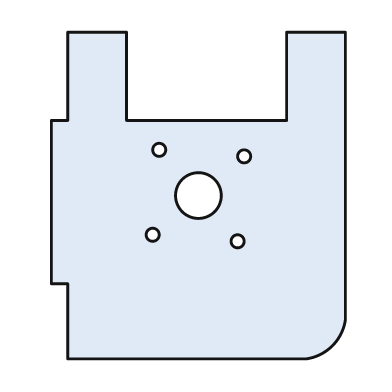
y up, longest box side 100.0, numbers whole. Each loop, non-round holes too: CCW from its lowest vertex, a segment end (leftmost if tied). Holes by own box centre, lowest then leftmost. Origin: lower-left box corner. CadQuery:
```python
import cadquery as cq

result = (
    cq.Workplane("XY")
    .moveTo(5.0, 0.0)
    .lineTo(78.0, 0.0)
    .threePointArc((86.0, 4.0), (90.0, 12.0))
    .lineTo(90.0, 100.0)
    .lineTo(72.0, 100.0)
    .lineTo(72.0, 73.0)
    .lineTo(23.0, 73.0)
    .lineTo(23.0, 100.0)
    .lineTo(5.0, 100.0)
    .lineTo(5.0, 73.0)
    .lineTo(0.0, 73.0)
    .lineTo(0.0, 23.0)
    .lineTo(5.0, 23.0)
    .close()
    .moveTo(57.0, 36.0)
    .circle(2.0)
    .moveTo(31.0, 38.0)
    .circle(2.0)
    .moveTo(45.0, 50.0)
    .circle(7.0)
    .moveTo(59.0, 62.0)
    .circle(2.0)
    .moveTo(33.0, 64.0)
    .circle(2.0)
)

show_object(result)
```